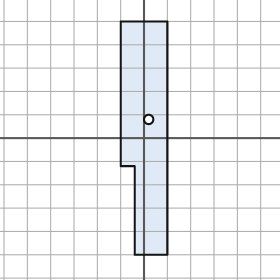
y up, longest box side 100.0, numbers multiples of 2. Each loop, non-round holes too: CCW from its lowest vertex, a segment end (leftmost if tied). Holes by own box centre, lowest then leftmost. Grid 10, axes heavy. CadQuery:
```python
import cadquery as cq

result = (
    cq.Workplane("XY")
    .moveTo(-4.0, -50.0)
    .lineTo(10.0, -50.0)
    .lineTo(10.0, 50.0)
    .lineTo(-10.0, 50.0)
    .lineTo(-10.0, -12.0)
    .lineTo(-4.0, -12.0)
    .close()
    .moveTo(2.0, 8.0)
    .circle(2.0)
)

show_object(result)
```